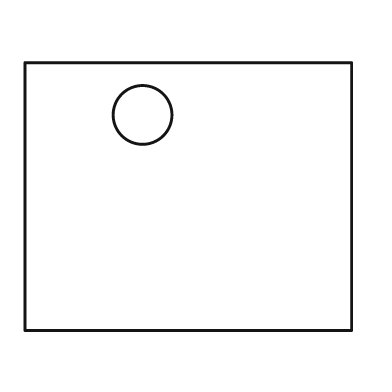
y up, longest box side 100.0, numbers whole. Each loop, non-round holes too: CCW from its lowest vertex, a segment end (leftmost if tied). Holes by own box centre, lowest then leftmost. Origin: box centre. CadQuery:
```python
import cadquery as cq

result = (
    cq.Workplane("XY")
    .moveTo(-50.0, -41.0)
    .lineTo(50.0, -41.0)
    .lineTo(50.0, 41.0)
    .lineTo(-50.0, 41.0)
    .close()
    .moveTo(-14.0, 25.0)
    .circle(9.0)
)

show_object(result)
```